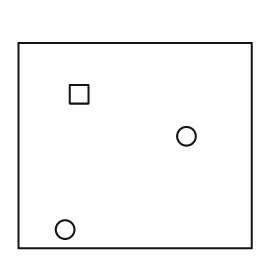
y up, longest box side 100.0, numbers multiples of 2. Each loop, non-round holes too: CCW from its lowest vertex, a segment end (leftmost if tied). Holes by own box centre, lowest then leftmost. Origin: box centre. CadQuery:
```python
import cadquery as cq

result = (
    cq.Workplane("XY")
    .moveTo(-50.0, -44.0)
    .lineTo(50.0, -44.0)
    .lineTo(50.0, 44.0)
    .lineTo(-50.0, 44.0)
    .close()
    .moveTo(-30.0, -36.0)
    .circle(4.0)
    .moveTo(22.0, 4.0)
    .circle(4.0)
    .moveTo(-28.0, 18.0)
    .lineTo(-20.0, 18.0)
    .lineTo(-20.0, 26.0)
    .lineTo(-28.0, 26.0)
    .close()
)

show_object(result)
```